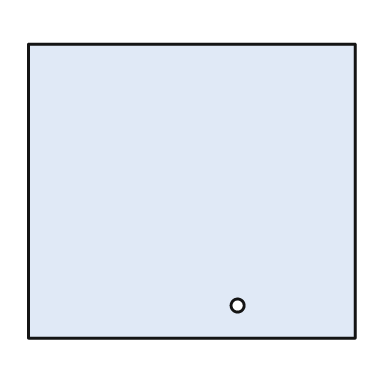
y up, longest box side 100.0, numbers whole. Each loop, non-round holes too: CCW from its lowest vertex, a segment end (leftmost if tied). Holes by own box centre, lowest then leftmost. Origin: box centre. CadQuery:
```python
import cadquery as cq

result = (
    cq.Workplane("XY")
    .moveTo(-50.0, -45.0)
    .lineTo(50.0, -45.0)
    .lineTo(50.0, 45.0)
    .lineTo(-50.0, 45.0)
    .close()
    .moveTo(14.0, -35.0)
    .circle(2.0)
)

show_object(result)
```